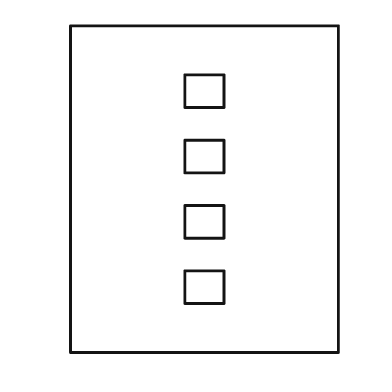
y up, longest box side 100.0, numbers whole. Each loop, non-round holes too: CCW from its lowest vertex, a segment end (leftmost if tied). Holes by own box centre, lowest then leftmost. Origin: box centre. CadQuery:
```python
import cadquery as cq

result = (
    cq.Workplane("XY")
    .moveTo(-41.0, -50.0)
    .lineTo(41.0, -50.0)
    .lineTo(41.0, 50.0)
    .lineTo(-41.0, 50.0)
    .close()
    .moveTo(-6.0, -35.0)
    .lineTo(6.0, -35.0)
    .lineTo(6.0, -25.0)
    .lineTo(-6.0, -25.0)
    .close()
    .moveTo(-6.0, -15.0)
    .lineTo(6.0, -15.0)
    .lineTo(6.0, -5.0)
    .lineTo(-6.0, -5.0)
    .close()
    .moveTo(-6.0, 5.0)
    .lineTo(6.0, 5.0)
    .lineTo(6.0, 15.0)
    .lineTo(-6.0, 15.0)
    .close()
    .moveTo(-6.0, 25.0)
    .lineTo(6.0, 25.0)
    .lineTo(6.0, 35.0)
    .lineTo(-6.0, 35.0)
    .close()
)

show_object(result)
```